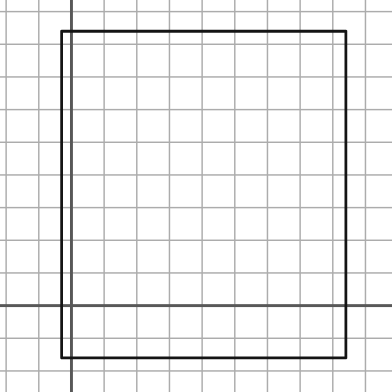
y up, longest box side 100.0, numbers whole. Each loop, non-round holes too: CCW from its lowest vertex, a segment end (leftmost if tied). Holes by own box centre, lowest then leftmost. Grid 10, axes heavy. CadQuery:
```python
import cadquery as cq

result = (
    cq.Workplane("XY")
    .moveTo(-3.0, -16.0)
    .lineTo(84.0, -16.0)
    .lineTo(84.0, 84.0)
    .lineTo(-3.0, 84.0)
    .close()
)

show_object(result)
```